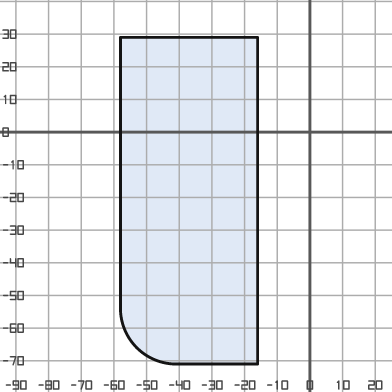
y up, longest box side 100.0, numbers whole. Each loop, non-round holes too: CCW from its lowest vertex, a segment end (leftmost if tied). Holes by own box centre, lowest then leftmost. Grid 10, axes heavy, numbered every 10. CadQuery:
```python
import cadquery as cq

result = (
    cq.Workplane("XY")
    .moveTo(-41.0, -71.0)
    .lineTo(-16.0, -71.0)
    .lineTo(-16.0, 29.0)
    .lineTo(-58.0, 29.0)
    .lineTo(-58.0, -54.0)
    .threePointArc((-53.0, -66.0), (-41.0, -71.0))
    .close()
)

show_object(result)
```